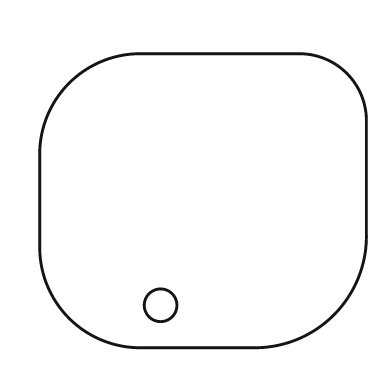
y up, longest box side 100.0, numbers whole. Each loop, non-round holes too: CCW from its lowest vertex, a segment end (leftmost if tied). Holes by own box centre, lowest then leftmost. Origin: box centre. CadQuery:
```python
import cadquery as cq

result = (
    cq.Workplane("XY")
    .moveTo(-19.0, -45.0)
    .lineTo(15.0, -45.0)
    .threePointArc((40.0, -35.0), (50.0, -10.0))
    .lineTo(50.0, 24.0)
    .threePointArc((44.0, 39.0), (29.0, 45.0))
    .lineTo(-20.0, 45.0)
    .threePointArc((-41.0, 36.0), (-50.0, 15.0))
    .lineTo(-50.0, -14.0)
    .threePointArc((-41.0, -36.0), (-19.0, -45.0))
    .close()
    .moveTo(-13.0, -32.0)
    .circle(5.0)
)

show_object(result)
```